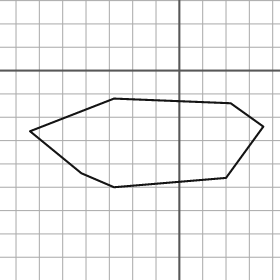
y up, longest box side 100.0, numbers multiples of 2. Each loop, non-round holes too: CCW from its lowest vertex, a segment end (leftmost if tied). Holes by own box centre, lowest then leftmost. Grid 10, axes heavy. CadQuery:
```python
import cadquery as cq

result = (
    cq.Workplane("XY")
    .moveTo(-28.0, -50.0)
    .lineTo(20.0, -46.0)
    .lineTo(36.0, -24.0)
    .lineTo(22.0, -14.0)
    .lineTo(-28.0, -12.0)
    .lineTo(-64.0, -26.0)
    .lineTo(-42.0, -44.0)
    .close()
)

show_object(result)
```